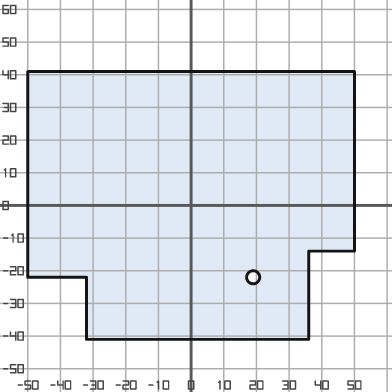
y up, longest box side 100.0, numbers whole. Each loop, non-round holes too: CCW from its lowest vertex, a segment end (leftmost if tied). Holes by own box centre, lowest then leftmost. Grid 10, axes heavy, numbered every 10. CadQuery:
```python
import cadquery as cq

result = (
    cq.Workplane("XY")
    .moveTo(-32.0, -41.0)
    .lineTo(36.0, -41.0)
    .lineTo(36.0, -14.0)
    .lineTo(50.0, -14.0)
    .lineTo(50.0, 41.0)
    .lineTo(-50.0, 41.0)
    .lineTo(-50.0, -22.0)
    .lineTo(-32.0, -22.0)
    .close()
    .moveTo(19.0, -22.0)
    .circle(2.0)
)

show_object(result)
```